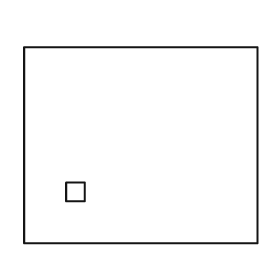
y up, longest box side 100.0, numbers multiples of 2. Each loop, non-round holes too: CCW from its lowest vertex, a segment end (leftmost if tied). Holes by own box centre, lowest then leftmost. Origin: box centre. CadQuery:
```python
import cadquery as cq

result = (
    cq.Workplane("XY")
    .moveTo(-50.0, -42.0)
    .lineTo(50.0, -42.0)
    .lineTo(50.0, 42.0)
    .lineTo(-50.0, 42.0)
    .close()
    .moveTo(-32.0, -24.0)
    .lineTo(-24.0, -24.0)
    .lineTo(-24.0, -16.0)
    .lineTo(-32.0, -16.0)
    .close()
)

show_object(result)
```